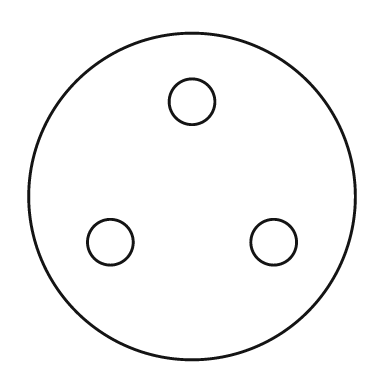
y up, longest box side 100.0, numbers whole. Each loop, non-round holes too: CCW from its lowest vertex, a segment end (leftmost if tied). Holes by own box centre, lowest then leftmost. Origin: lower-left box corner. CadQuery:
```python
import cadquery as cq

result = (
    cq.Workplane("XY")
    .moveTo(50.0, 50.0)
    .circle(50.0)
    .moveTo(25.0, 36.0)
    .circle(7.0)
    .moveTo(75.0, 36.0)
    .circle(7.0)
    .moveTo(50.0, 79.0)
    .circle(7.0)
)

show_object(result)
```